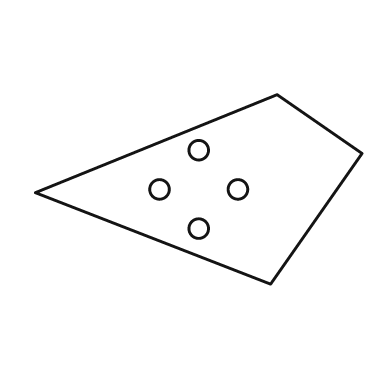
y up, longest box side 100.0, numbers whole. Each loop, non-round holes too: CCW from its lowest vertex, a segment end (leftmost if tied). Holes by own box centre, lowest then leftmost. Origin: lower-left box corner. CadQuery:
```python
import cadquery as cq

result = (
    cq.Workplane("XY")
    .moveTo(72.0, 0.0)
    .lineTo(100.0, 40.0)
    .lineTo(74.0, 58.0)
    .lineTo(0.0, 28.0)
    .close()
    .moveTo(50.0, 17.0)
    .circle(3.0)
    .moveTo(38.0, 29.0)
    .circle(3.0)
    .moveTo(62.0, 29.0)
    .circle(3.0)
    .moveTo(50.0, 41.0)
    .circle(3.0)
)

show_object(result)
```